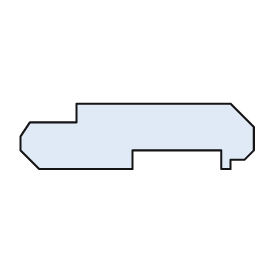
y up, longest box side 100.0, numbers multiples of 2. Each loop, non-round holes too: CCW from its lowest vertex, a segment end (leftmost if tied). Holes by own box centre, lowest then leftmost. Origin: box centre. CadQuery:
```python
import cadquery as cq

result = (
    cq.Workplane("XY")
    .moveTo(-42.0, -14.0)
    .lineTo(-2.0, -14.0)
    .lineTo(-2.0, -6.0)
    .lineTo(36.0, -6.0)
    .lineTo(36.0, -14.0)
    .lineTo(40.0, -14.0)
    .lineTo(40.0, -10.0)
    .lineTo(46.0, -10.0)
    .lineTo(50.0, -6.0)
    .lineTo(50.0, 4.0)
    .lineTo(40.0, 14.0)
    .lineTo(-26.0, 14.0)
    .lineTo(-26.0, 6.0)
    .lineTo(-46.0, 6.0)
    .lineTo(-50.0, 0.0)
    .lineTo(-50.0, -6.0)
    .close()
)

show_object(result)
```